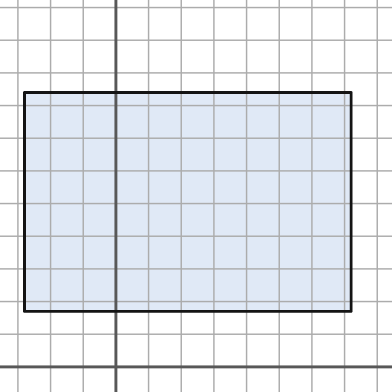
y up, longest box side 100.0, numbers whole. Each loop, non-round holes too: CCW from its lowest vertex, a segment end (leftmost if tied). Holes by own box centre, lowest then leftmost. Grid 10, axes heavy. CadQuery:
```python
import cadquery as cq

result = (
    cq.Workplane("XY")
    .moveTo(-28.0, 17.0)
    .lineTo(72.0, 17.0)
    .lineTo(72.0, 84.0)
    .lineTo(-28.0, 84.0)
    .close()
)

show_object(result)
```